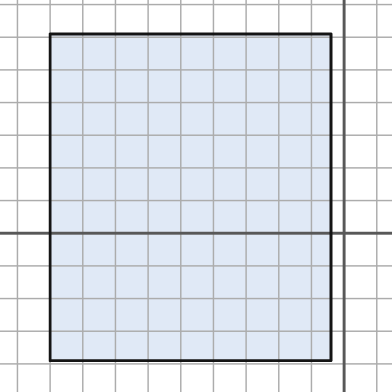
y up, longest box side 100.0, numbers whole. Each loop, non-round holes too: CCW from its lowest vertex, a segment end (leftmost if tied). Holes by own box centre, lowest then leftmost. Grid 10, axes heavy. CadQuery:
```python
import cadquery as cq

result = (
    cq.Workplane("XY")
    .moveTo(-90.0, -39.0)
    .lineTo(-4.0, -39.0)
    .lineTo(-4.0, 61.0)
    .lineTo(-90.0, 61.0)
    .close()
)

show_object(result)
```